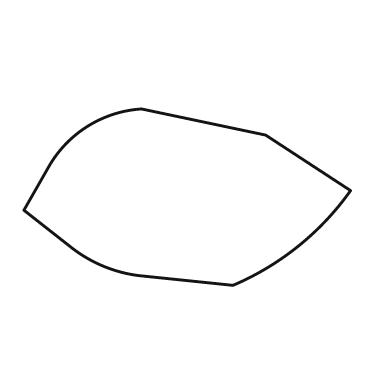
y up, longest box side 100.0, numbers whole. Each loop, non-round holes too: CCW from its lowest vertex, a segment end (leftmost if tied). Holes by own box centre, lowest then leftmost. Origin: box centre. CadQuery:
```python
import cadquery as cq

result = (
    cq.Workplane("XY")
    .moveTo(14.0, -27.0)
    .threePointArc((34.0, -15.0), (50.0, 2.0))
    .lineTo(24.0, 19.0)
    .lineTo(-14.0, 27.0)
    .threePointArc((-30.0, 22.0), (-42.0, 10.0))
    .lineTo(-50.0, -4.0)
    .lineTo(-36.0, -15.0)
    .threePointArc((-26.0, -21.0), (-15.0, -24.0))
    .close()
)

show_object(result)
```